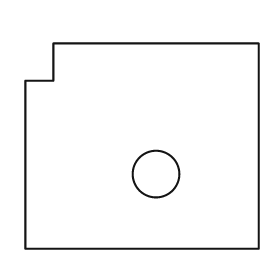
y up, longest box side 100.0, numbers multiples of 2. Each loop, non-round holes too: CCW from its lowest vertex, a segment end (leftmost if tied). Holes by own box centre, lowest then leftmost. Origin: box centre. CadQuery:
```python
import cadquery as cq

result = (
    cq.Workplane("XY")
    .moveTo(-50.0, -44.0)
    .lineTo(50.0, -44.0)
    .lineTo(50.0, 44.0)
    .lineTo(-38.0, 44.0)
    .lineTo(-38.0, 28.0)
    .lineTo(-50.0, 28.0)
    .close()
    .moveTo(6.0, -12.0)
    .circle(10.0)
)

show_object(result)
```